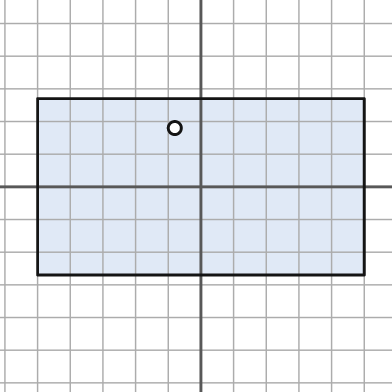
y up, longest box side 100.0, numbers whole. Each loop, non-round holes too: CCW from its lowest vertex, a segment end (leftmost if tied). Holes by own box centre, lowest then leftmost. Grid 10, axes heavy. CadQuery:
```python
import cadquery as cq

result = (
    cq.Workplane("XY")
    .moveTo(-50.0, -27.0)
    .lineTo(50.0, -27.0)
    .lineTo(50.0, 27.0)
    .lineTo(-50.0, 27.0)
    .close()
    .moveTo(-8.0, 18.0)
    .circle(2.0)
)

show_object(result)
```